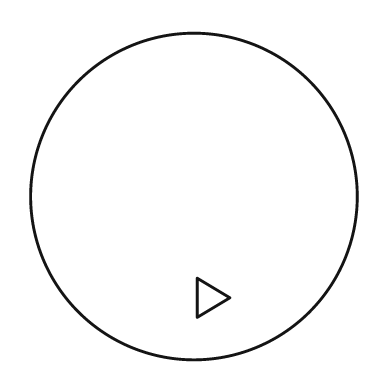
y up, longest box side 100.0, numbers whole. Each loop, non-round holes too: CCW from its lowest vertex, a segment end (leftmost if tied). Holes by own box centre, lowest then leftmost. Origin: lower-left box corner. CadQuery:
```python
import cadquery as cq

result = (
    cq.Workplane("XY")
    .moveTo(50.0, 50.0)
    .circle(50.0)
    .moveTo(51.0, 13.0)
    .lineTo(61.0, 19.0)
    .lineTo(51.0, 25.0)
    .close()
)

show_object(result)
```